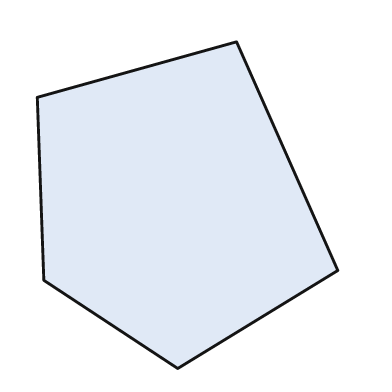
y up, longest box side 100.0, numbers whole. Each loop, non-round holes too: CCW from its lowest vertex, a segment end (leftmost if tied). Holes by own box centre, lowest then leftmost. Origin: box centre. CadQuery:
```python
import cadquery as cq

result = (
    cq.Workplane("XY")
    .moveTo(-3.0, -50.0)
    .lineTo(46.0, -20.0)
    .lineTo(15.0, 50.0)
    .lineTo(-46.0, 33.0)
    .lineTo(-44.0, -23.0)
    .close()
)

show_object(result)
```